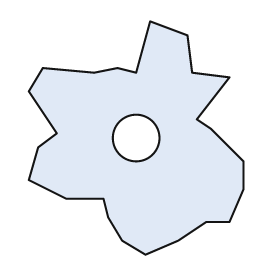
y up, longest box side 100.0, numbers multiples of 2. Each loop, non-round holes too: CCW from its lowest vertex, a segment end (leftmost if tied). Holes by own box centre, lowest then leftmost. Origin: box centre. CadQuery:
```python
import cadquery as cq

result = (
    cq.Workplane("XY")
    .moveTo(4.0, -50.0)
    .lineTo(18.0, -44.0)
    .lineTo(30.0, -36.0)
    .lineTo(40.0, -36.0)
    .lineTo(46.0, -22.0)
    .lineTo(46.0, -10.0)
    .lineTo(32.0, 4.0)
    .lineTo(26.0, 8.0)
    .lineTo(40.0, 26.0)
    .lineTo(24.0, 28.0)
    .lineTo(22.0, 44.0)
    .lineTo(6.0, 50.0)
    .lineTo(0.0, 28.0)
    .lineTo(-8.0, 30.0)
    .lineTo(-18.0, 28.0)
    .lineTo(-40.0, 30.0)
    .lineTo(-46.0, 20.0)
    .lineTo(-34.0, 2.0)
    .lineTo(-42.0, -4.0)
    .lineTo(-46.0, -18.0)
    .lineTo(-30.0, -26.0)
    .lineTo(-14.0, -26.0)
    .lineTo(-12.0, -34.0)
    .lineTo(-6.0, -44.0)
    .close()
    .moveTo(0.0, 0.0)
    .circle(10.0)
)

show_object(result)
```